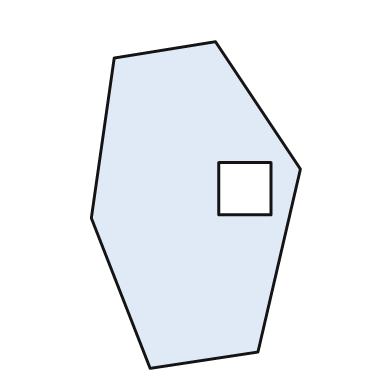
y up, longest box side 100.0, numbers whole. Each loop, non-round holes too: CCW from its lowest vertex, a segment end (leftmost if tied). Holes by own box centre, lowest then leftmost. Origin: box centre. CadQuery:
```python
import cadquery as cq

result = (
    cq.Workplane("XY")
    .moveTo(-14.0, -50.0)
    .lineTo(19.0, -45.0)
    .lineTo(32.0, 11.0)
    .lineTo(6.0, 50.0)
    .lineTo(-25.0, 45.0)
    .lineTo(-32.0, -4.0)
    .close()
    .moveTo(7.0, -3.0)
    .lineTo(23.0, -3.0)
    .lineTo(23.0, 13.0)
    .lineTo(7.0, 13.0)
    .close()
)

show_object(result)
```